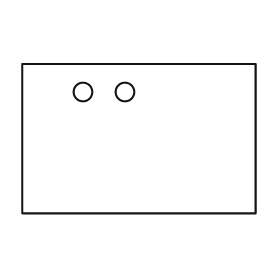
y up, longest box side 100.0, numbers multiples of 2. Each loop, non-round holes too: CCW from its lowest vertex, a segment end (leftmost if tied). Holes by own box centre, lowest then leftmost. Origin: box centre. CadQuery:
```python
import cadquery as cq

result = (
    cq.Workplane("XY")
    .moveTo(-50.0, -32.0)
    .lineTo(50.0, -32.0)
    .lineTo(50.0, 32.0)
    .lineTo(-50.0, 32.0)
    .close()
    .moveTo(-24.0, 20.0)
    .circle(4.0)
    .moveTo(-6.0, 20.0)
    .circle(4.0)
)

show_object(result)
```